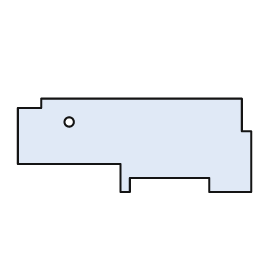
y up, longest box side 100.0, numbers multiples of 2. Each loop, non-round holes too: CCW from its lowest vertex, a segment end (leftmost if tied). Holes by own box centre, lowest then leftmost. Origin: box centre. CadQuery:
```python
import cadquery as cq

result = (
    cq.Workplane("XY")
    .moveTo(-6.0, -20.0)
    .lineTo(-2.0, -20.0)
    .lineTo(-2.0, -14.0)
    .lineTo(32.0, -14.0)
    .lineTo(32.0, -20.0)
    .lineTo(50.0, -20.0)
    .lineTo(50.0, 6.0)
    .lineTo(46.0, 6.0)
    .lineTo(46.0, 20.0)
    .lineTo(-40.0, 20.0)
    .lineTo(-40.0, 16.0)
    .lineTo(-50.0, 16.0)
    .lineTo(-50.0, -8.0)
    .lineTo(-6.0, -8.0)
    .close()
    .moveTo(-28.0, 10.0)
    .circle(2.0)
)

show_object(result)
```